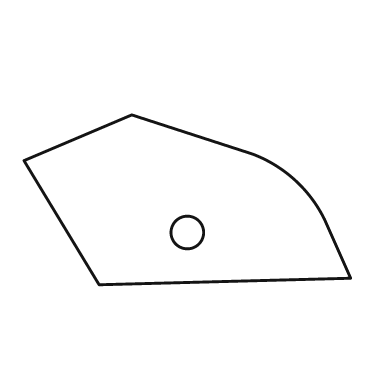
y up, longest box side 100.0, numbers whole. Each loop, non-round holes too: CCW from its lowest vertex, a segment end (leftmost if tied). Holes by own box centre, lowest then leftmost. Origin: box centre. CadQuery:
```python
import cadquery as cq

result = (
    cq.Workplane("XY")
    .moveTo(-27.0, -26.0)
    .lineTo(50.0, -24.0)
    .lineTo(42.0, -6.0)
    .threePointArc((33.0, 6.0), (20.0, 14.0))
    .lineTo(-17.0, 26.0)
    .lineTo(-50.0, 12.0)
    .close()
    .moveTo(0.0, -10.0)
    .circle(5.0)
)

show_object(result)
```